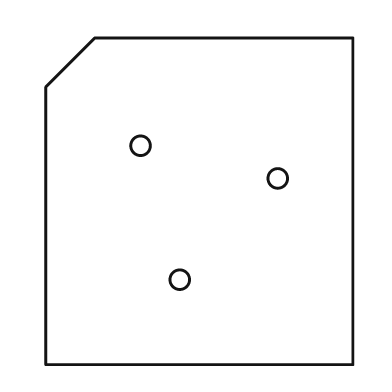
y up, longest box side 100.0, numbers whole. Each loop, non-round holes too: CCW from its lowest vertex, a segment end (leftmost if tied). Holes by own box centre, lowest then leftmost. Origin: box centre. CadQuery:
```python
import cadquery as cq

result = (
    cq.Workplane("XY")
    .moveTo(-47.0, -50.0)
    .lineTo(47.0, -50.0)
    .lineTo(47.0, 50.0)
    .lineTo(-32.0, 50.0)
    .lineTo(-47.0, 35.0)
    .close()
    .moveTo(-6.0, -24.0)
    .circle(3.0)
    .moveTo(24.0, 7.0)
    .circle(3.0)
    .moveTo(-18.0, 17.0)
    .circle(3.0)
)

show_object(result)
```